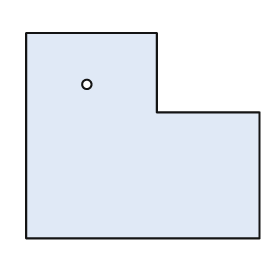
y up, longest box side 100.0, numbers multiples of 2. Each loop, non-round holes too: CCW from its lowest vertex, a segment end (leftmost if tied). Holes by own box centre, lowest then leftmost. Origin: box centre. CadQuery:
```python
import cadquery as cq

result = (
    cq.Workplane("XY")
    .moveTo(-50.0, -44.0)
    .lineTo(50.0, -44.0)
    .lineTo(50.0, 10.0)
    .lineTo(6.0, 10.0)
    .lineTo(6.0, 44.0)
    .lineTo(-50.0, 44.0)
    .close()
    .moveTo(-24.0, 22.0)
    .circle(2.0)
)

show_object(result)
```